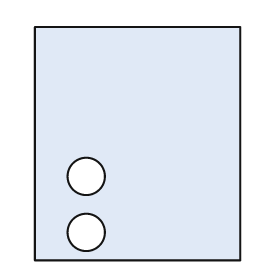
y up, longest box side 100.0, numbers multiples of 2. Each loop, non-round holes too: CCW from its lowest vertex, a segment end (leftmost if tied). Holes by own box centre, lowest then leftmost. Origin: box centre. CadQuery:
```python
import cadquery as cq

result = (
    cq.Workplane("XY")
    .moveTo(-44.0, -50.0)
    .lineTo(44.0, -50.0)
    .lineTo(44.0, 50.0)
    .lineTo(-44.0, 50.0)
    .close()
    .moveTo(-22.0, -38.0)
    .circle(8.0)
    .moveTo(-22.0, -14.0)
    .circle(8.0)
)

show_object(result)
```